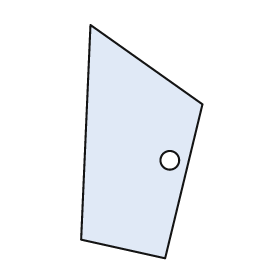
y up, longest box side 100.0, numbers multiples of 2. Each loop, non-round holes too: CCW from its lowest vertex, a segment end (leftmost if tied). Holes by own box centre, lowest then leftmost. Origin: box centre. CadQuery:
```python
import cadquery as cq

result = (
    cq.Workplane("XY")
    .moveTo(10.0, -50.0)
    .lineTo(26.0, 16.0)
    .lineTo(-22.0, 50.0)
    .lineTo(-26.0, -42.0)
    .close()
    .moveTo(12.0, -8.0)
    .circle(4.0)
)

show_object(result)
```